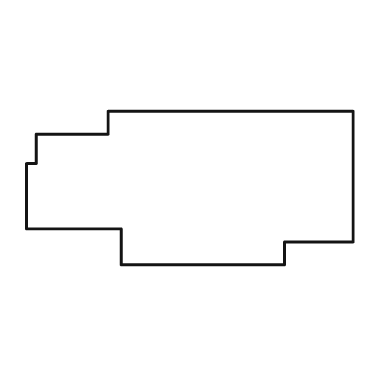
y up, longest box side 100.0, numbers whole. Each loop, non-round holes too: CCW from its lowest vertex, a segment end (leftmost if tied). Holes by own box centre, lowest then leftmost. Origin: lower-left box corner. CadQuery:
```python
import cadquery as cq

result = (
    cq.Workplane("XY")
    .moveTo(29.0, 0.0)
    .lineTo(79.0, 0.0)
    .lineTo(79.0, 7.0)
    .lineTo(100.0, 7.0)
    .lineTo(100.0, 47.0)
    .lineTo(25.0, 47.0)
    .lineTo(25.0, 40.0)
    .lineTo(3.0, 40.0)
    .lineTo(3.0, 31.0)
    .lineTo(0.0, 31.0)
    .lineTo(0.0, 11.0)
    .lineTo(29.0, 11.0)
    .close()
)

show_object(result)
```